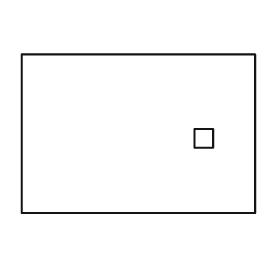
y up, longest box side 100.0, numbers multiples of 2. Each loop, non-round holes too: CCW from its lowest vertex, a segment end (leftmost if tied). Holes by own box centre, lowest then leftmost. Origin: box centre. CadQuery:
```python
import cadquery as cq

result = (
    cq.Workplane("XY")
    .moveTo(-50.0, -34.0)
    .lineTo(50.0, -34.0)
    .lineTo(50.0, 34.0)
    .lineTo(-50.0, 34.0)
    .close()
    .moveTo(24.0, -6.0)
    .lineTo(32.0, -6.0)
    .lineTo(32.0, 2.0)
    .lineTo(24.0, 2.0)
    .close()
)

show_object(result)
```